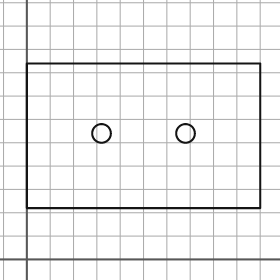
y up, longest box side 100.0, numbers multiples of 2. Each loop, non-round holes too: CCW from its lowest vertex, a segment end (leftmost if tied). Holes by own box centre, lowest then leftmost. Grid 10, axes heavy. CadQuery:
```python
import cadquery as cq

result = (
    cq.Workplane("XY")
    .moveTo(0.0, 22.0)
    .lineTo(100.0, 22.0)
    .lineTo(100.0, 84.0)
    .lineTo(0.0, 84.0)
    .close()
    .moveTo(32.0, 54.0)
    .circle(4.0)
    .moveTo(68.0, 54.0)
    .circle(4.0)
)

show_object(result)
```